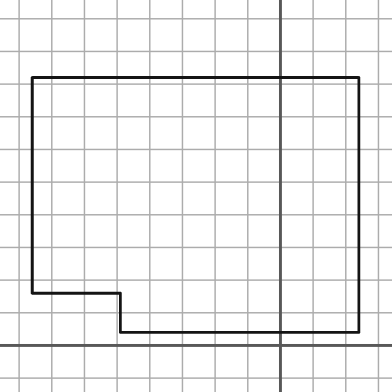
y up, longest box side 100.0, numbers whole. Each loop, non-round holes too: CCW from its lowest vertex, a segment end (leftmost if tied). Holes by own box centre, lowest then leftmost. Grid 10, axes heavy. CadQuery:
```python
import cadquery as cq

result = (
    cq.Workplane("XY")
    .moveTo(-49.0, 4.0)
    .lineTo(24.0, 4.0)
    .lineTo(24.0, 82.0)
    .lineTo(-76.0, 82.0)
    .lineTo(-76.0, 16.0)
    .lineTo(-49.0, 16.0)
    .close()
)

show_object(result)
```